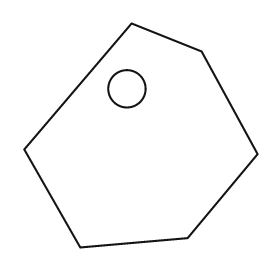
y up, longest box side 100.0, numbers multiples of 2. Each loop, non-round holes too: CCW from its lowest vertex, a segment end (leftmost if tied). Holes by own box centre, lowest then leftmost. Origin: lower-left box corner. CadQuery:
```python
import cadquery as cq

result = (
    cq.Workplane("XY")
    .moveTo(24.0, 0.0)
    .lineTo(70.0, 4.0)
    .lineTo(100.0, 40.0)
    .lineTo(76.0, 84.0)
    .lineTo(46.0, 96.0)
    .lineTo(0.0, 42.0)
    .close()
    .moveTo(44.0, 68.0)
    .circle(8.0)
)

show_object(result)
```